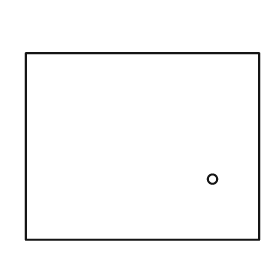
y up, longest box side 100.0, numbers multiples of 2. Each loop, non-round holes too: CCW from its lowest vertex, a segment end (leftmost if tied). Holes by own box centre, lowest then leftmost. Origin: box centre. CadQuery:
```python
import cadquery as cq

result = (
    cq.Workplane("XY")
    .moveTo(-50.0, -40.0)
    .lineTo(50.0, -40.0)
    .lineTo(50.0, 40.0)
    .lineTo(-50.0, 40.0)
    .close()
    .moveTo(30.0, -14.0)
    .circle(2.0)
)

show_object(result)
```